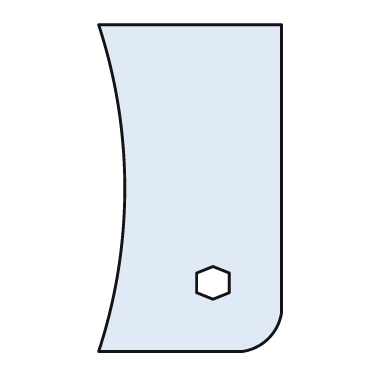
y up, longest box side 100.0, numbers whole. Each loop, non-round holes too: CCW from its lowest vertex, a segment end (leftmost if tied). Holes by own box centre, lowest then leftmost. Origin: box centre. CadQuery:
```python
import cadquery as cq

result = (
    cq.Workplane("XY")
    .moveTo(-28.0, -50.0)
    .lineTo(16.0, -50.0)
    .threePointArc((24.0, -46.0), (28.0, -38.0))
    .lineTo(28.0, 50.0)
    .lineTo(-28.0, 50.0)
    .threePointArc((-20.0, 0.0), (-28.0, -50.0))
    .close()
    .moveTo(7.0, -34.0)
    .lineTo(12.0, -32.0)
    .lineTo(12.0, -26.0)
    .lineTo(7.0, -24.0)
    .lineTo(2.0, -26.0)
    .lineTo(2.0, -32.0)
    .close()
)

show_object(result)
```